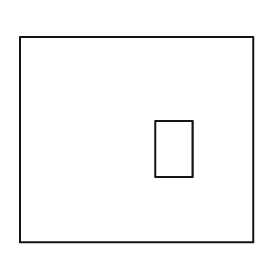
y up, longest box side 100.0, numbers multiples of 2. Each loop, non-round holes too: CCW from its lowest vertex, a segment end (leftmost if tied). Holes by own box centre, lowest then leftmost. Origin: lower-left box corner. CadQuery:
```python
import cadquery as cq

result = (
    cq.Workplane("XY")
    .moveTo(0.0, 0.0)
    .lineTo(100.0, 0.0)
    .lineTo(100.0, 88.0)
    .lineTo(0.0, 88.0)
    .close()
    .moveTo(58.0, 28.0)
    .lineTo(74.0, 28.0)
    .lineTo(74.0, 52.0)
    .lineTo(58.0, 52.0)
    .close()
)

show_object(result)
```